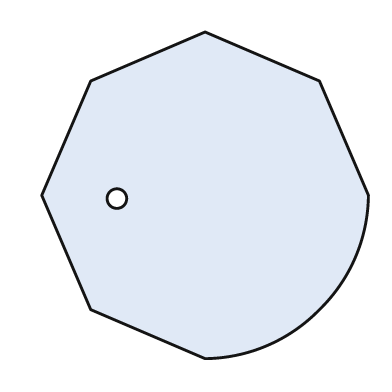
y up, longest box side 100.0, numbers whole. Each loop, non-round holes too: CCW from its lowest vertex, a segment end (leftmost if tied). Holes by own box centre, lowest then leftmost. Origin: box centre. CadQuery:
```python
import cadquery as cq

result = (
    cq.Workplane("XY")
    .moveTo(0.0, -50.0)
    .threePointArc((19.0, -46.0), (35.0, -35.0))
    .threePointArc((46.0, -19.0), (50.0, 0.0))
    .lineTo(35.0, 35.0)
    .lineTo(0.0, 50.0)
    .lineTo(-35.0, 35.0)
    .lineTo(-50.0, 0.0)
    .lineTo(-35.0, -35.0)
    .close()
    .moveTo(-27.0, -1.0)
    .circle(3.0)
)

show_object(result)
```